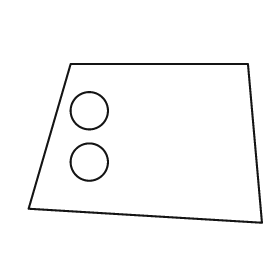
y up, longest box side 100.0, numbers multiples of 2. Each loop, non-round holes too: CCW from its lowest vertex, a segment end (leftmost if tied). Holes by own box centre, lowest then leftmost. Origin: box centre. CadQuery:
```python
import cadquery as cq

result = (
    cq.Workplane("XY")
    .moveTo(50.0, -34.0)
    .lineTo(44.0, 34.0)
    .lineTo(-32.0, 34.0)
    .lineTo(-50.0, -28.0)
    .close()
    .moveTo(-24.0, -8.0)
    .circle(8.0)
    .moveTo(-24.0, 14.0)
    .circle(8.0)
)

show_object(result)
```